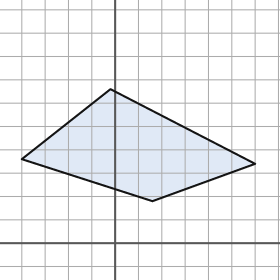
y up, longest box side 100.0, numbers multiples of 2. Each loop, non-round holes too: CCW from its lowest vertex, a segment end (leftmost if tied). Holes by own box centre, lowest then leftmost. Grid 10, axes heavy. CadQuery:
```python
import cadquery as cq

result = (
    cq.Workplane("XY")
    .moveTo(16.0, 18.0)
    .lineTo(60.0, 34.0)
    .lineTo(-2.0, 66.0)
    .lineTo(-40.0, 36.0)
    .close()
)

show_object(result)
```